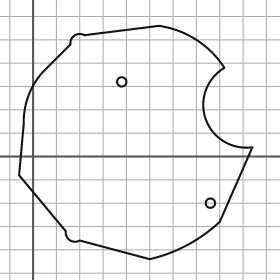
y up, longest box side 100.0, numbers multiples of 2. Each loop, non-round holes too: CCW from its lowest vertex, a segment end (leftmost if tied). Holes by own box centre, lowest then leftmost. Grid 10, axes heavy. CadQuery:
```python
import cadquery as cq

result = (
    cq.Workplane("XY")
    .moveTo(50.0, -44.0)
    .threePointArc((66.0, -38.0), (80.0, -28.0))
    .lineTo(94.0, 4.0)
    .threePointArc((74.0, 16.0), (82.0, 38.0))
    .threePointArc((70.0, 50.0), (54.0, 56.0))
    .lineTo(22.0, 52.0)
    .threePointArc((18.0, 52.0), (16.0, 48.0))
    .lineTo(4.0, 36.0)
    .threePointArc((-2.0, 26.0), (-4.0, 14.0))
    .lineTo(-6.0, -8.0)
    .lineTo(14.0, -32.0)
    .threePointArc((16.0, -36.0), (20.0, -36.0))
    .close()
    .moveTo(76.0, -20.0)
    .circle(2.0)
    .moveTo(38.0, 32.0)
    .circle(2.0)
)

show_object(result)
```